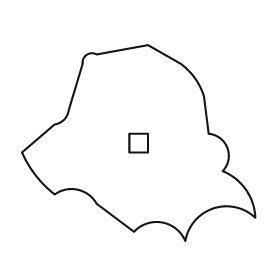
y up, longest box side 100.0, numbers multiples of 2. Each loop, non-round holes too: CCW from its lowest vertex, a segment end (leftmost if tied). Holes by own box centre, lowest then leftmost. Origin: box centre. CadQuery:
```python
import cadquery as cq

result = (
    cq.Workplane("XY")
    .moveTo(20.0, -42.0)
    .threePointArc((32.0, -28.0), (50.0, -32.0))
    .threePointArc((46.0, -20.0), (36.0, -12.0))
    .threePointArc((38.0, -2.0), (30.0, 4.0))
    .lineTo(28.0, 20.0)
    .threePointArc((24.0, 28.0), (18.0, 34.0))
    .lineTo(4.0, 42.0)
    .lineTo(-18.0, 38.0)
    .threePointArc((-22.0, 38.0), (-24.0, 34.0))
    .lineTo(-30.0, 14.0)
    .threePointArc((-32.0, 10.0), (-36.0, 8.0))
    .lineTo(-50.0, -4.0)
    .threePointArc((-44.0, -14.0), (-36.0, -22.0))
    .threePointArc((-26.0, -20.0), (-18.0, -26.0))
    .lineTo(-2.0, -38.0)
    .threePointArc((10.0, -34.0), (20.0, -42.0))
    .close()
    .moveTo(-4.0, -4.0)
    .lineTo(4.0, -4.0)
    .lineTo(4.0, 4.0)
    .lineTo(-4.0, 4.0)
    .close()
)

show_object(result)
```